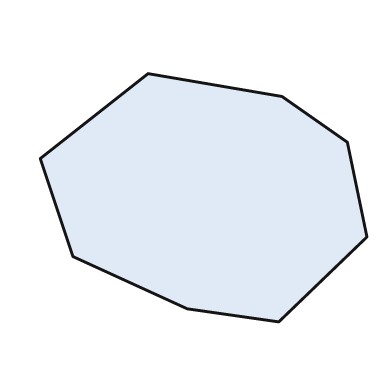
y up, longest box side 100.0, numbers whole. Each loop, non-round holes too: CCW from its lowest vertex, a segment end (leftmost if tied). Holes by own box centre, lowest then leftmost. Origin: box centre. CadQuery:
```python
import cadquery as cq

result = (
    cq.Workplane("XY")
    .moveTo(23.0, -38.0)
    .lineTo(50.0, -12.0)
    .lineTo(44.0, 17.0)
    .lineTo(24.0, 31.0)
    .lineTo(-17.0, 38.0)
    .lineTo(-50.0, 12.0)
    .lineTo(-40.0, -18.0)
    .lineTo(-5.0, -34.0)
    .close()
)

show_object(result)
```